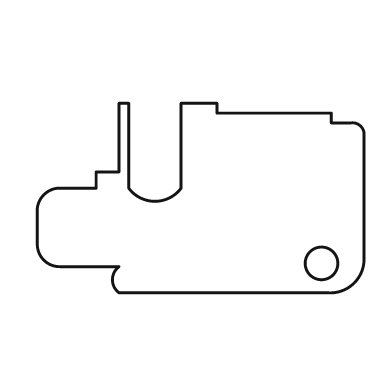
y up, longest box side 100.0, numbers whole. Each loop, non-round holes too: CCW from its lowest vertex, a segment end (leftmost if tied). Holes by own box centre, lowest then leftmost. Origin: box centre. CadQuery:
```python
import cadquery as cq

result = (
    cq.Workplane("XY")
    .moveTo(-25.0, -29.0)
    .lineTo(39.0, -29.0)
    .threePointArc((47.0, -26.0), (50.0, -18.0))
    .lineTo(50.0, 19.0)
    .threePointArc((49.0, 22.0), (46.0, 23.0))
    .lineTo(40.0, 23.0)
    .lineTo(40.0, 26.0)
    .lineTo(5.0, 26.0)
    .lineTo(5.0, 29.0)
    .lineTo(-6.0, 29.0)
    .lineTo(-6.0, 3.0)
    .threePointArc((-14.0, -1.0), (-22.0, 3.0))
    .lineTo(-22.0, 29.0)
    .lineTo(-25.0, 29.0)
    .lineTo(-25.0, 8.0)
    .lineTo(-32.0, 8.0)
    .lineTo(-32.0, 3.0)
    .lineTo(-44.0, 3.0)
    .threePointArc((-48.0, 1.0), (-50.0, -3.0))
    .lineTo(-50.0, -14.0)
    .threePointArc((-48.0, -19.0), (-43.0, -21.0))
    .lineTo(-25.0, -21.0)
    .threePointArc((-27.0, -25.0), (-25.0, -29.0))
    .close()
    .moveTo(37.0, -20.0)
    .circle(5.0)
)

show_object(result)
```